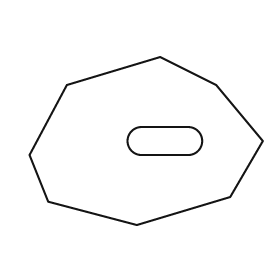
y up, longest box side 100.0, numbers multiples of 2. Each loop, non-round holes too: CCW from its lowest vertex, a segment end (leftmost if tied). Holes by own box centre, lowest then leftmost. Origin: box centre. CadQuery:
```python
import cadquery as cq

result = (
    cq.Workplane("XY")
    .moveTo(-4.0, -36.0)
    .lineTo(36.0, -24.0)
    .lineTo(50.0, 0.0)
    .lineTo(30.0, 24.0)
    .lineTo(6.0, 36.0)
    .lineTo(-34.0, 24.0)
    .lineTo(-50.0, -6.0)
    .lineTo(-42.0, -26.0)
    .close()
    .moveTo(-2.0, -6.0)
    .lineTo(18.0, -6.0)
    .threePointArc((24.0, 0.0), (18.0, 6.0))
    .lineTo(-2.0, 6.0)
    .threePointArc((-8.0, 0.0), (-2.0, -6.0))
    .close()
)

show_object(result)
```